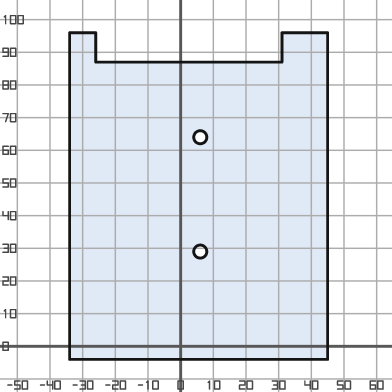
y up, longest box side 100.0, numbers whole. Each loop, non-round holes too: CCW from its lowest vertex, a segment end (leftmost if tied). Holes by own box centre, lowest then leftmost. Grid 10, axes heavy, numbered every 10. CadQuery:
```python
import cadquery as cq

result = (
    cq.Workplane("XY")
    .moveTo(-34.0, -4.0)
    .lineTo(45.0, -4.0)
    .lineTo(45.0, 96.0)
    .lineTo(31.0, 96.0)
    .lineTo(31.0, 87.0)
    .lineTo(-26.0, 87.0)
    .lineTo(-26.0, 96.0)
    .lineTo(-34.0, 96.0)
    .close()
    .moveTo(6.0, 29.0)
    .circle(2.0)
    .moveTo(6.0, 64.0)
    .circle(2.0)
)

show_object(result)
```